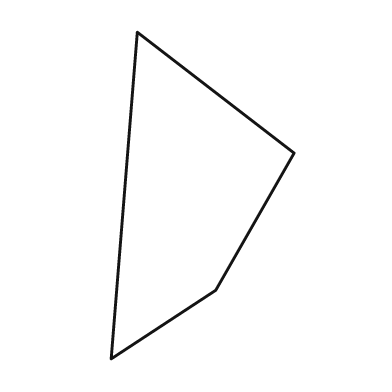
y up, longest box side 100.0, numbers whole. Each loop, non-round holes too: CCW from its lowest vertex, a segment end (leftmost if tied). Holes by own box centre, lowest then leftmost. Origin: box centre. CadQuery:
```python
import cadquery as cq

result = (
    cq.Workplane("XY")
    .moveTo(-28.0, -50.0)
    .lineTo(4.0, -29.0)
    .lineTo(28.0, 13.0)
    .lineTo(-20.0, 50.0)
    .close()
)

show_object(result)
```